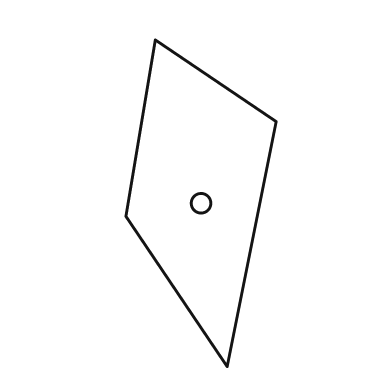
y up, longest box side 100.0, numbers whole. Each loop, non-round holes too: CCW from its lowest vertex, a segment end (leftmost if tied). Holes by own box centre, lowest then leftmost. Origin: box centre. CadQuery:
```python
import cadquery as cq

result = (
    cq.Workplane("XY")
    .moveTo(8.0, -50.0)
    .lineTo(23.0, 25.0)
    .lineTo(-14.0, 50.0)
    .lineTo(-23.0, -4.0)
    .close()
    .moveTo(0.0, 0.0)
    .circle(3.0)
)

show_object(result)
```